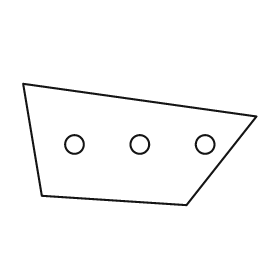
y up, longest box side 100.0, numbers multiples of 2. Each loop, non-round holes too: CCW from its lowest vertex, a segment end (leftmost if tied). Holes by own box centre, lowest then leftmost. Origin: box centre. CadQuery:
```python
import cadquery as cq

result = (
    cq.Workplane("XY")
    .moveTo(20.0, -26.0)
    .lineTo(50.0, 12.0)
    .lineTo(-50.0, 26.0)
    .lineTo(-42.0, -22.0)
    .close()
    .moveTo(-28.0, 0.0)
    .circle(4.0)
    .moveTo(0.0, 0.0)
    .circle(4.0)
    .moveTo(28.0, 0.0)
    .circle(4.0)
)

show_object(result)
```